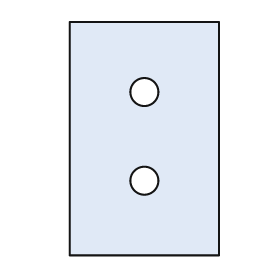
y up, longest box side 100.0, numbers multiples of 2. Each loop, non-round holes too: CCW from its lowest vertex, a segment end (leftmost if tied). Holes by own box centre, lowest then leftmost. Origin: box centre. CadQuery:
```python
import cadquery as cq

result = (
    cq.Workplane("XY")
    .moveTo(-32.0, -50.0)
    .lineTo(32.0, -50.0)
    .lineTo(32.0, 50.0)
    .lineTo(-32.0, 50.0)
    .close()
    .moveTo(0.0, -18.0)
    .circle(6.0)
    .moveTo(0.0, 20.0)
    .circle(6.0)
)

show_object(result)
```